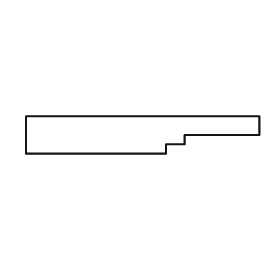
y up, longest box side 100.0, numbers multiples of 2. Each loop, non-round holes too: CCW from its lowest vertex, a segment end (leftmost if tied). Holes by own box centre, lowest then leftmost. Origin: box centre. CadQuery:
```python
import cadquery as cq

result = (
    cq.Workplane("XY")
    .moveTo(-50.0, -8.0)
    .lineTo(10.0, -8.0)
    .lineTo(10.0, -4.0)
    .lineTo(18.0, -4.0)
    .lineTo(18.0, 0.0)
    .lineTo(50.0, 0.0)
    .lineTo(50.0, 8.0)
    .lineTo(-50.0, 8.0)
    .close()
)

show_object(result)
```